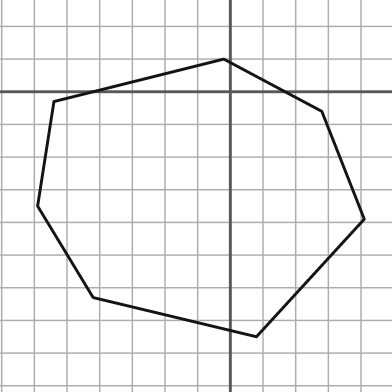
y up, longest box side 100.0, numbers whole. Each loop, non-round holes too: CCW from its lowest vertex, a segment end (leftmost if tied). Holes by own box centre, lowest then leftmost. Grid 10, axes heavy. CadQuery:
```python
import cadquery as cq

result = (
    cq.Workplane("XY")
    .moveTo(8.0, -75.0)
    .lineTo(41.0, -39.0)
    .lineTo(28.0, -6.0)
    .lineTo(-2.0, 10.0)
    .lineTo(-54.0, -3.0)
    .lineTo(-59.0, -35.0)
    .lineTo(-42.0, -63.0)
    .close()
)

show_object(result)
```